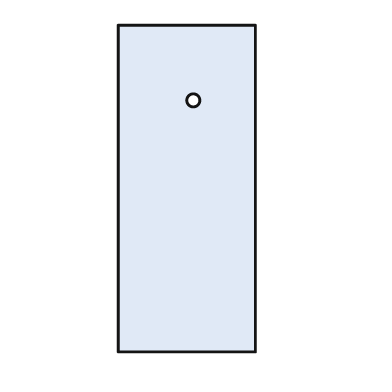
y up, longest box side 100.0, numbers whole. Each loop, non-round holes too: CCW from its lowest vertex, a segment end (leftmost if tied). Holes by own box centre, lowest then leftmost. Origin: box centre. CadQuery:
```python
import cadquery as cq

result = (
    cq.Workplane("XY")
    .moveTo(-21.0, -50.0)
    .lineTo(21.0, -50.0)
    .lineTo(21.0, 50.0)
    .lineTo(-21.0, 50.0)
    .close()
    .moveTo(2.0, 27.0)
    .circle(2.0)
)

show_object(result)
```